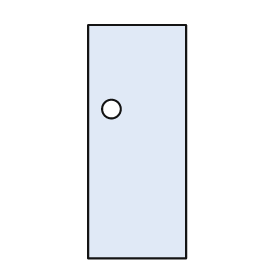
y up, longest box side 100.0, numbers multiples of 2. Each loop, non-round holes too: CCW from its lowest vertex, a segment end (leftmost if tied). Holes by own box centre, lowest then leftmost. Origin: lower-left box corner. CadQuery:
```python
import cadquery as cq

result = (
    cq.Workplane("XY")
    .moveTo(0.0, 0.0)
    .lineTo(42.0, 0.0)
    .lineTo(42.0, 100.0)
    .lineTo(0.0, 100.0)
    .close()
    .moveTo(10.0, 64.0)
    .circle(4.0)
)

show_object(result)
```